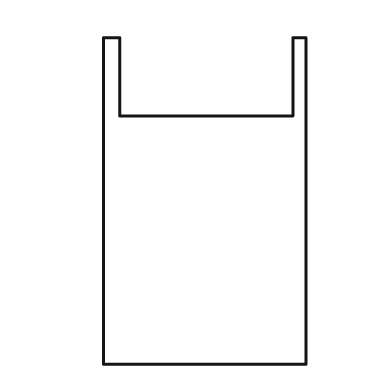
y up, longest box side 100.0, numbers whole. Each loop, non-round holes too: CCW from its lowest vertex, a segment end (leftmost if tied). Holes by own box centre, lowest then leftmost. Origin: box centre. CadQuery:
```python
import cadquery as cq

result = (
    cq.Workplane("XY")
    .moveTo(-31.0, -50.0)
    .lineTo(31.0, -50.0)
    .lineTo(31.0, 50.0)
    .lineTo(27.0, 50.0)
    .lineTo(27.0, 26.0)
    .lineTo(-26.0, 26.0)
    .lineTo(-26.0, 50.0)
    .lineTo(-31.0, 50.0)
    .close()
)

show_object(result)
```